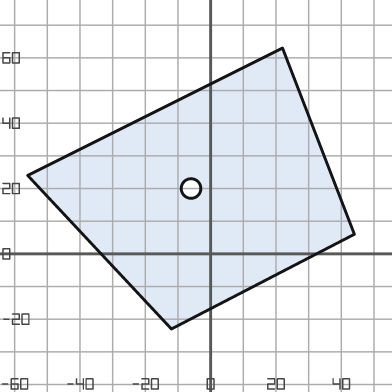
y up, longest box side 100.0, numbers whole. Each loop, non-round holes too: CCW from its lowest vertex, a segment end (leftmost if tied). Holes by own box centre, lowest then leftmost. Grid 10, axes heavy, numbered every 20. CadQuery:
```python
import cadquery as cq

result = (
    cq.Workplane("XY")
    .moveTo(-12.0, -23.0)
    .lineTo(44.0, 6.0)
    .lineTo(22.0, 63.0)
    .lineTo(-56.0, 24.0)
    .close()
    .moveTo(-6.0, 20.0)
    .circle(3.0)
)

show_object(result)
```